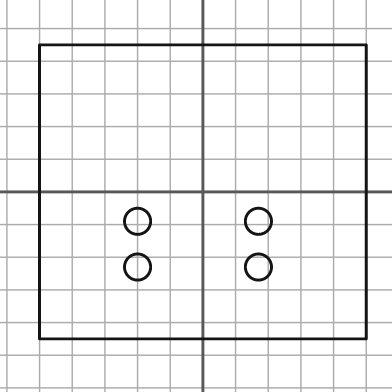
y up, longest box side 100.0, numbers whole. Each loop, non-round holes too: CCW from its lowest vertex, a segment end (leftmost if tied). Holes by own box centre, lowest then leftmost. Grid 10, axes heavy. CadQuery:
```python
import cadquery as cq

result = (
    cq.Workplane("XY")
    .moveTo(-50.0, -45.0)
    .lineTo(50.0, -45.0)
    .lineTo(50.0, 45.0)
    .lineTo(-50.0, 45.0)
    .close()
    .moveTo(-20.0, -23.0)
    .circle(4.0)
    .moveTo(17.0, -23.0)
    .circle(4.0)
    .moveTo(-20.0, -9.0)
    .circle(4.0)
    .moveTo(17.0, -9.0)
    .circle(4.0)
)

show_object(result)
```